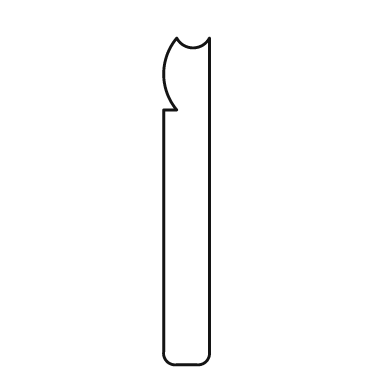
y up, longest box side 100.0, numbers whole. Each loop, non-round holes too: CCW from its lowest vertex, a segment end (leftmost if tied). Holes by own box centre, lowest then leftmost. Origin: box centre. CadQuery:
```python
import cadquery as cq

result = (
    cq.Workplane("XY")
    .moveTo(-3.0, -50.0)
    .lineTo(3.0, -50.0)
    .threePointArc((6.0, -49.0), (7.0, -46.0))
    .lineTo(7.0, 50.0)
    .threePointArc((2.0, 47.0), (-3.0, 50.0))
    .threePointArc((-7.0, 39.0), (-3.0, 28.0))
    .lineTo(-7.0, 28.0)
    .lineTo(-7.0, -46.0)
    .threePointArc((-6.0, -49.0), (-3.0, -50.0))
    .close()
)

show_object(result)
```